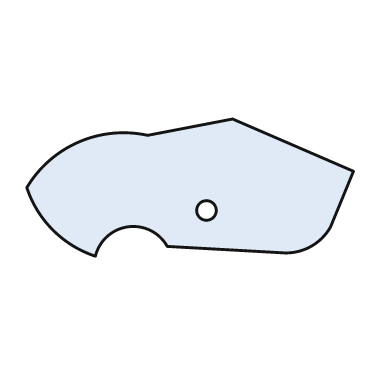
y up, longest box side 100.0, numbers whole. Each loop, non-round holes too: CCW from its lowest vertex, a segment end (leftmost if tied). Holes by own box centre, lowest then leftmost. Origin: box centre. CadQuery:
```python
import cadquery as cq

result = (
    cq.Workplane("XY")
    .moveTo(-29.0, -21.0)
    .threePointArc((-19.0, -12.0), (-7.0, -18.0))
    .lineTo(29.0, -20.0)
    .threePointArc((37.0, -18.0), (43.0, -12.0))
    .lineTo(50.0, 5.0)
    .lineTo(13.0, 21.0)
    .lineTo(-13.0, 16.0)
    .threePointArc((-34.0, 14.0), (-50.0, 0.0))
    .threePointArc((-42.0, -13.0), (-29.0, -21.0))
    .close()
    .moveTo(5.0, -7.0)
    .circle(3.0)
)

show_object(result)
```